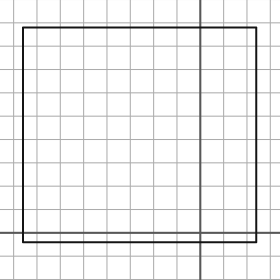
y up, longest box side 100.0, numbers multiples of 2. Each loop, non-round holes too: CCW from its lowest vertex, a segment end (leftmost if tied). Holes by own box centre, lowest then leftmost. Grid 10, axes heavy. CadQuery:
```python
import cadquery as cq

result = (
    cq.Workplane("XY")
    .moveTo(-76.0, -4.0)
    .lineTo(24.0, -4.0)
    .lineTo(24.0, 88.0)
    .lineTo(-76.0, 88.0)
    .close()
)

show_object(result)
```